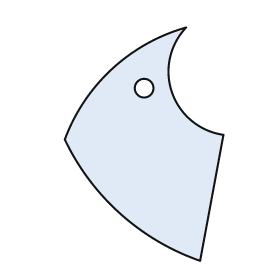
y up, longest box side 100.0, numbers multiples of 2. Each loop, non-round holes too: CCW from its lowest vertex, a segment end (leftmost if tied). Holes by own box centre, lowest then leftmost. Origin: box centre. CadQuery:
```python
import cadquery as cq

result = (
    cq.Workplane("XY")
    .moveTo(24.0, -50.0)
    .lineTo(34.0, 4.0)
    .threePointArc((12.0, 22.0), (18.0, 50.0))
    .threePointArc((-14.0, 32.0), (-34.0, 2.0))
    .threePointArc((-10.0, -30.0), (24.0, -50.0))
    .close()
    .moveTo(0.0, 24.0)
    .circle(4.0)
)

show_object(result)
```